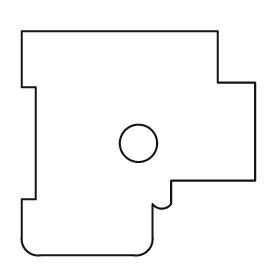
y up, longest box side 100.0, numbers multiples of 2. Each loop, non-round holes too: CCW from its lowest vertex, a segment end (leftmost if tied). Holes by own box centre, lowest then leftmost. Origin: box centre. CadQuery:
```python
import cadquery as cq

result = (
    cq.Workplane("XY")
    .moveTo(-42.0, -48.0)
    .lineTo(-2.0, -48.0)
    .threePointArc((4.0, -46.0), (6.0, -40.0))
    .lineTo(6.0, -26.0)
    .threePointArc((10.0, -28.0), (14.0, -26.0))
    .lineTo(14.0, -16.0)
    .lineTo(50.0, -16.0)
    .lineTo(50.0, 26.0)
    .lineTo(34.0, 26.0)
    .lineTo(34.0, 48.0)
    .lineTo(-50.0, 48.0)
    .lineTo(-50.0, 24.0)
    .lineTo(-44.0, 24.0)
    .lineTo(-44.0, -24.0)
    .lineTo(-50.0, -24.0)
    .lineTo(-50.0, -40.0)
    .threePointArc((-48.0, -46.0), (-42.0, -48.0))
    .close()
    .moveTo(0.0, 0.0)
    .circle(8.0)
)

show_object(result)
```